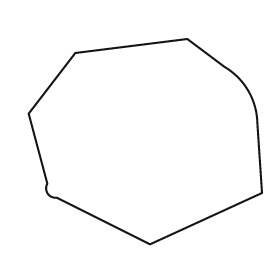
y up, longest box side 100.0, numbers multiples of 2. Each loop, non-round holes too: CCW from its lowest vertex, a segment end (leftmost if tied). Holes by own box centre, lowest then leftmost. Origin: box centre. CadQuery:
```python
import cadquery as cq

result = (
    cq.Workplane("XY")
    .moveTo(2.0, -44.0)
    .lineTo(50.0, -22.0)
    .lineTo(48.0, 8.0)
    .threePointArc((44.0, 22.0), (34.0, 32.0))
    .lineTo(18.0, 44.0)
    .lineTo(-30.0, 38.0)
    .lineTo(-50.0, 12.0)
    .lineTo(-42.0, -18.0)
    .threePointArc((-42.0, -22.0), (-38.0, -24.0))
    .close()
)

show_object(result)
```